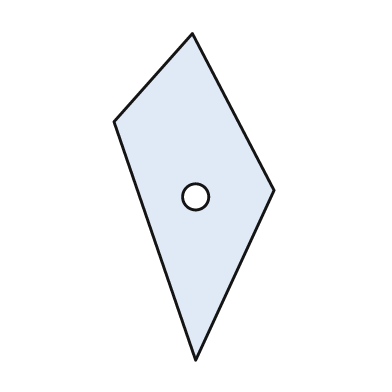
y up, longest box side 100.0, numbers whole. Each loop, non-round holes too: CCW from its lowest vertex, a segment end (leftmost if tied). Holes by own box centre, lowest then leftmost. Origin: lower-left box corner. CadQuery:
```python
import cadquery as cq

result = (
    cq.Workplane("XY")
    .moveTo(25.0, 0.0)
    .lineTo(49.0, 52.0)
    .lineTo(24.0, 100.0)
    .lineTo(0.0, 73.0)
    .close()
    .moveTo(25.0, 50.0)
    .circle(4.0)
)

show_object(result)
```